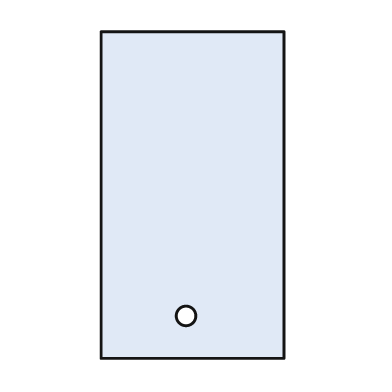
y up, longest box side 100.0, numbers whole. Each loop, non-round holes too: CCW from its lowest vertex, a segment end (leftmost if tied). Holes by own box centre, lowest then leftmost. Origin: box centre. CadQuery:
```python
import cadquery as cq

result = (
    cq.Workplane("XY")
    .moveTo(-28.0, -50.0)
    .lineTo(28.0, -50.0)
    .lineTo(28.0, 50.0)
    .lineTo(-28.0, 50.0)
    .close()
    .moveTo(-2.0, -37.0)
    .circle(3.0)
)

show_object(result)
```